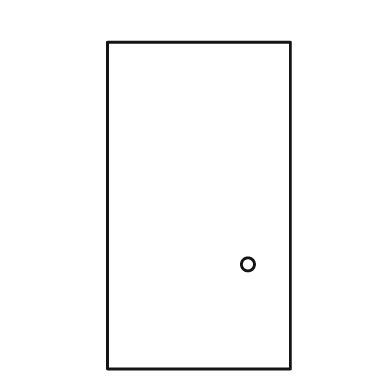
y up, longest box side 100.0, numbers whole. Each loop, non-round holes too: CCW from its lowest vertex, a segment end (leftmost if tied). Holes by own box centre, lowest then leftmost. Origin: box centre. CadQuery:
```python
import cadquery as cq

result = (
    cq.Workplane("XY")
    .moveTo(-28.0, -50.0)
    .lineTo(28.0, -50.0)
    .lineTo(28.0, 50.0)
    .lineTo(-28.0, 50.0)
    .close()
    .moveTo(15.0, -18.0)
    .circle(2.0)
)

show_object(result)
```